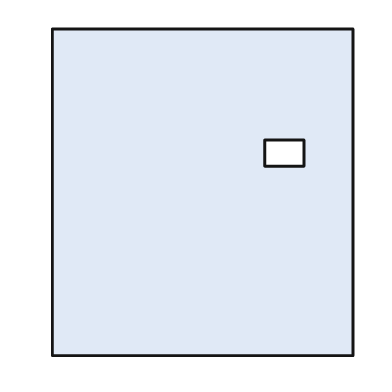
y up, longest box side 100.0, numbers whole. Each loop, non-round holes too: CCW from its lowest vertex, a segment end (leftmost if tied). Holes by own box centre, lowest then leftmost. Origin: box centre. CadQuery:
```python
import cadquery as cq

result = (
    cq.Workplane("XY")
    .moveTo(-46.0, -50.0)
    .lineTo(46.0, -50.0)
    .lineTo(46.0, 50.0)
    .lineTo(-46.0, 50.0)
    .close()
    .moveTo(19.0, 8.0)
    .lineTo(31.0, 8.0)
    .lineTo(31.0, 16.0)
    .lineTo(19.0, 16.0)
    .close()
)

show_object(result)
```